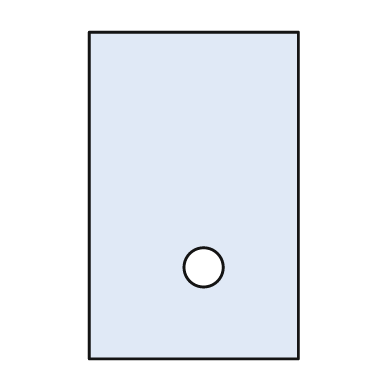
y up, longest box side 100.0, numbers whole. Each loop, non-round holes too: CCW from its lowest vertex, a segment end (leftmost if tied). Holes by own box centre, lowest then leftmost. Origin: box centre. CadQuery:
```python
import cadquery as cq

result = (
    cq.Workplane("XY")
    .moveTo(-32.0, -50.0)
    .lineTo(32.0, -50.0)
    .lineTo(32.0, 50.0)
    .lineTo(-32.0, 50.0)
    .close()
    .moveTo(3.0, -22.0)
    .circle(6.0)
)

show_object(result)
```